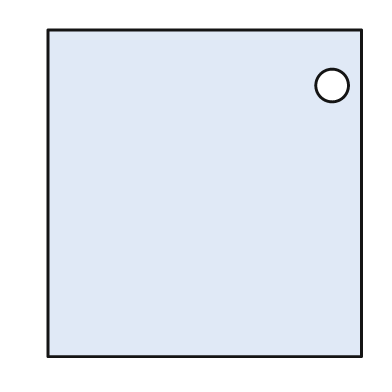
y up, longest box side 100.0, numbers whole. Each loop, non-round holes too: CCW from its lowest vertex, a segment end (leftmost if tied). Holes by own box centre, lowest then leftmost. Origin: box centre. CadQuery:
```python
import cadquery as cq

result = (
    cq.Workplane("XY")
    .moveTo(-48.0, -50.0)
    .lineTo(48.0, -50.0)
    .lineTo(48.0, 50.0)
    .lineTo(-48.0, 50.0)
    .close()
    .moveTo(39.0, 33.0)
    .circle(5.0)
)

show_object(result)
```